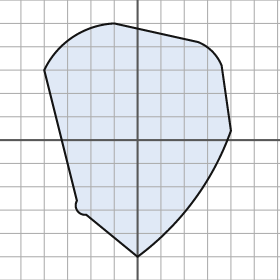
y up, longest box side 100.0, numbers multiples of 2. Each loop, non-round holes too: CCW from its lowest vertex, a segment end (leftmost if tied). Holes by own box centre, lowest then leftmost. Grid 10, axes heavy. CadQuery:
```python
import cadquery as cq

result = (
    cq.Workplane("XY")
    .moveTo(0.0, -50.0)
    .threePointArc((24.0, -26.0), (40.0, 4.0))
    .lineTo(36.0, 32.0)
    .threePointArc((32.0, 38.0), (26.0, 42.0))
    .lineTo(-10.0, 50.0)
    .threePointArc((-28.0, 44.0), (-40.0, 30.0))
    .lineTo(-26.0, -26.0)
    .threePointArc((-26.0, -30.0), (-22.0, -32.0))
    .close()
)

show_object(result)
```